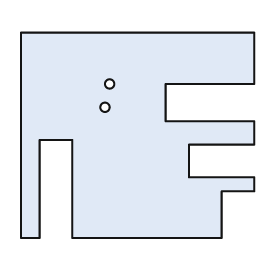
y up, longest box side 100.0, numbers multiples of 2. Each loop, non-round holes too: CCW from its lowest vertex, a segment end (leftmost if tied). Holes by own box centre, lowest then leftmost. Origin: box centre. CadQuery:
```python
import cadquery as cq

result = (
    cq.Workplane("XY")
    .moveTo(-50.0, -44.0)
    .lineTo(-42.0, -44.0)
    .lineTo(-42.0, -2.0)
    .lineTo(-28.0, -2.0)
    .lineTo(-28.0, -44.0)
    .lineTo(36.0, -44.0)
    .lineTo(36.0, -24.0)
    .lineTo(50.0, -24.0)
    .lineTo(50.0, -18.0)
    .lineTo(22.0, -18.0)
    .lineTo(22.0, -4.0)
    .lineTo(50.0, -4.0)
    .lineTo(50.0, 6.0)
    .lineTo(12.0, 6.0)
    .lineTo(12.0, 22.0)
    .lineTo(50.0, 22.0)
    .lineTo(50.0, 44.0)
    .lineTo(-50.0, 44.0)
    .close()
    .moveTo(-14.0, 12.0)
    .circle(2.0)
    .moveTo(-12.0, 22.0)
    .circle(2.0)
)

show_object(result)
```